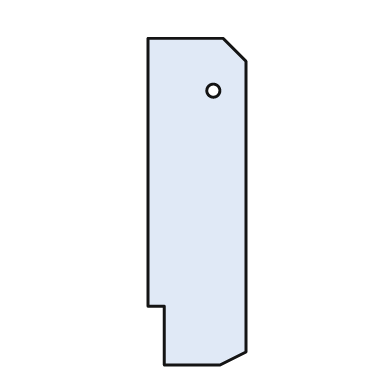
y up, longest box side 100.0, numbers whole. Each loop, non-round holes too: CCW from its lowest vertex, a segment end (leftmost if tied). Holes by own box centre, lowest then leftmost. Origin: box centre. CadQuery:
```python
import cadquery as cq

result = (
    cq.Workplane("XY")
    .moveTo(-10.0, -50.0)
    .lineTo(7.0, -50.0)
    .lineTo(15.0, -46.0)
    .lineTo(15.0, 43.0)
    .lineTo(8.0, 50.0)
    .lineTo(-15.0, 50.0)
    .lineTo(-15.0, -32.0)
    .lineTo(-10.0, -32.0)
    .close()
    .moveTo(5.0, 34.0)
    .circle(2.0)
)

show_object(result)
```